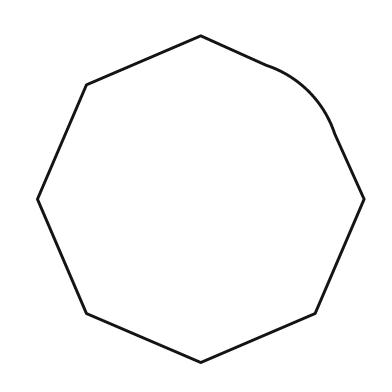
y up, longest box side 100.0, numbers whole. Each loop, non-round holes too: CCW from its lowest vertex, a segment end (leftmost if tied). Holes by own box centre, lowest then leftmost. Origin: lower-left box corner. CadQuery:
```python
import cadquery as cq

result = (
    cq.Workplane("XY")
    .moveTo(50.0, 0.0)
    .lineTo(85.0, 15.0)
    .lineTo(100.0, 50.0)
    .lineTo(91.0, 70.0)
    .threePointArc((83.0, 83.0), (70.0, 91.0))
    .lineTo(50.0, 100.0)
    .lineTo(15.0, 85.0)
    .lineTo(0.0, 50.0)
    .lineTo(15.0, 15.0)
    .close()
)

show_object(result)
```